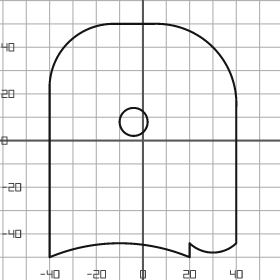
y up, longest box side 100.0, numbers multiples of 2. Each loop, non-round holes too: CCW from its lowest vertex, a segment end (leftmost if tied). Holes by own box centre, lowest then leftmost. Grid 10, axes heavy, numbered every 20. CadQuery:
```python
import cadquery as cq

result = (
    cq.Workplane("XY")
    .moveTo(-40.0, -50.0)
    .threePointArc((-10.0, -44.0), (20.0, -50.0))
    .lineTo(20.0, -44.0)
    .threePointArc((30.0, -48.0), (40.0, -44.0))
    .lineTo(40.0, 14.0)
    .threePointArc((30.0, 40.0), (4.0, 50.0))
    .lineTo(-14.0, 50.0)
    .threePointArc((-32.0, 42.0), (-40.0, 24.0))
    .close()
    .moveTo(-4.0, 8.0)
    .circle(6.0)
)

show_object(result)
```